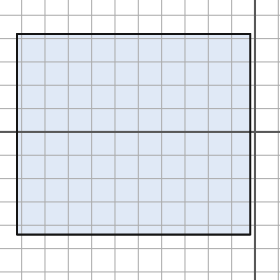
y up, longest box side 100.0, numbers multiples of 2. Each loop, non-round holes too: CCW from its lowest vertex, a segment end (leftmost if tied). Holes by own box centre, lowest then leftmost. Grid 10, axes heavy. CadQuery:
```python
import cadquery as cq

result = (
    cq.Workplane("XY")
    .moveTo(-102.0, -44.0)
    .lineTo(-2.0, -44.0)
    .lineTo(-2.0, 42.0)
    .lineTo(-102.0, 42.0)
    .close()
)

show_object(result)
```